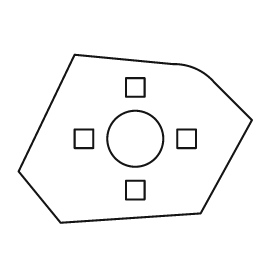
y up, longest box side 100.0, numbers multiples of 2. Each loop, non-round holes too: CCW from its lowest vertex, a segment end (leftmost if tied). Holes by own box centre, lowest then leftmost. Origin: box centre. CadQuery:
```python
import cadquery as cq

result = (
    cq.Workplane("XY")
    .moveTo(-32.0, -36.0)
    .lineTo(28.0, -32.0)
    .lineTo(50.0, 8.0)
    .lineTo(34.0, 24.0)
    .threePointArc((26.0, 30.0), (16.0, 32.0))
    .lineTo(-26.0, 36.0)
    .lineTo(-50.0, -14.0)
    .close()
    .moveTo(-4.0, -26.0)
    .lineTo(4.0, -26.0)
    .lineTo(4.0, -18.0)
    .lineTo(-4.0, -18.0)
    .close()
    .moveTo(-26.0, -4.0)
    .lineTo(-18.0, -4.0)
    .lineTo(-18.0, 4.0)
    .lineTo(-26.0, 4.0)
    .close()
    .moveTo(0.0, 0.0)
    .circle(12.0)
    .moveTo(18.0, -4.0)
    .lineTo(26.0, -4.0)
    .lineTo(26.0, 4.0)
    .lineTo(18.0, 4.0)
    .close()
    .moveTo(-4.0, 18.0)
    .lineTo(4.0, 18.0)
    .lineTo(4.0, 26.0)
    .lineTo(-4.0, 26.0)
    .close()
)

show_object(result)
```